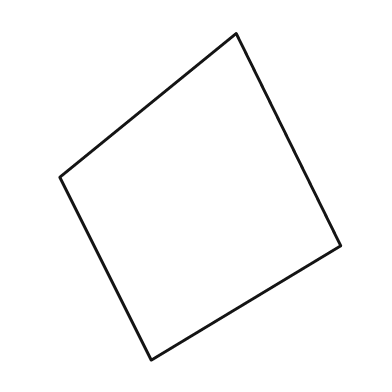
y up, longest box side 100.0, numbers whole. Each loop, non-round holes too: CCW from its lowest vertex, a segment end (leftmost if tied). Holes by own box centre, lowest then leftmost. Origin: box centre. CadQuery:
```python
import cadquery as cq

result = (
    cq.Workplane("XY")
    .moveTo(-15.0, -50.0)
    .lineTo(43.0, -15.0)
    .lineTo(11.0, 50.0)
    .lineTo(-43.0, 6.0)
    .close()
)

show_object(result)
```